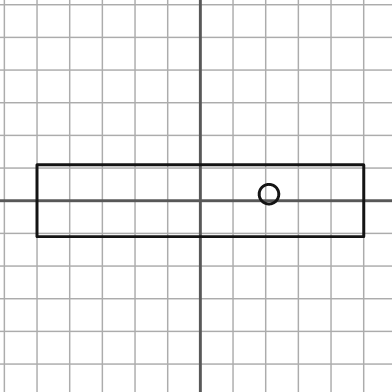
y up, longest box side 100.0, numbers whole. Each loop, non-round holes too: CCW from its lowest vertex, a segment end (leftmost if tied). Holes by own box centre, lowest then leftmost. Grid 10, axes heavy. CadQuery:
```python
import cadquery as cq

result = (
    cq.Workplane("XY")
    .moveTo(-50.0, -11.0)
    .lineTo(50.0, -11.0)
    .lineTo(50.0, 11.0)
    .lineTo(-50.0, 11.0)
    .close()
    .moveTo(21.0, 2.0)
    .circle(3.0)
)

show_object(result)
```